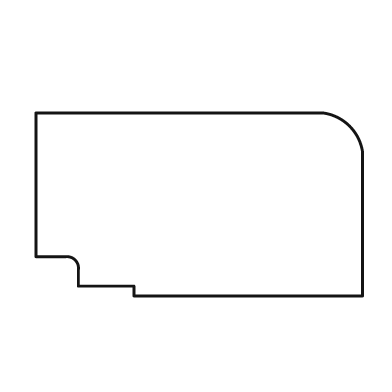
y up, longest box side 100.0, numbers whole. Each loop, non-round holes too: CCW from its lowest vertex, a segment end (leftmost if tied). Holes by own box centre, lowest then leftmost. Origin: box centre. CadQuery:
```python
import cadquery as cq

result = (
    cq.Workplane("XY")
    .moveTo(-20.0, -28.0)
    .lineTo(50.0, -28.0)
    .lineTo(50.0, 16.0)
    .threePointArc((46.0, 24.0), (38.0, 28.0))
    .lineTo(-50.0, 28.0)
    .lineTo(-50.0, -16.0)
    .lineTo(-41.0, -16.0)
    .threePointArc((-38.0, -17.0), (-37.0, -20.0))
    .lineTo(-37.0, -25.0)
    .lineTo(-20.0, -25.0)
    .close()
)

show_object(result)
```